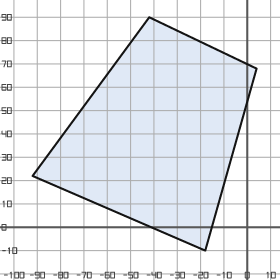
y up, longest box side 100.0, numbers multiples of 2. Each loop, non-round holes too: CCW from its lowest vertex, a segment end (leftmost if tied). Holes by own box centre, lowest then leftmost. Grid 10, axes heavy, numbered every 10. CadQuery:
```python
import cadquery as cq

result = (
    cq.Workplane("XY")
    .moveTo(-18.0, -10.0)
    .lineTo(4.0, 68.0)
    .lineTo(-42.0, 90.0)
    .lineTo(-92.0, 22.0)
    .close()
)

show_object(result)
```